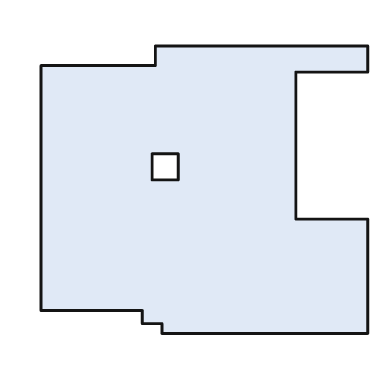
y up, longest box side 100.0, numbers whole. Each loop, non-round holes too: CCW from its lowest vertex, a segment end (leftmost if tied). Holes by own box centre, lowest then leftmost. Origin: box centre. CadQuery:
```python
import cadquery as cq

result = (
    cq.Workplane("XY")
    .moveTo(-13.0, -44.0)
    .lineTo(50.0, -44.0)
    .lineTo(50.0, -9.0)
    .lineTo(28.0, -9.0)
    .lineTo(28.0, 36.0)
    .lineTo(50.0, 36.0)
    .lineTo(50.0, 44.0)
    .lineTo(-15.0, 44.0)
    .lineTo(-15.0, 38.0)
    .lineTo(-50.0, 38.0)
    .lineTo(-50.0, -37.0)
    .lineTo(-19.0, -37.0)
    .lineTo(-19.0, -41.0)
    .lineTo(-13.0, -41.0)
    .close()
    .moveTo(-16.0, 3.0)
    .lineTo(-8.0, 3.0)
    .lineTo(-8.0, 11.0)
    .lineTo(-16.0, 11.0)
    .close()
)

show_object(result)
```